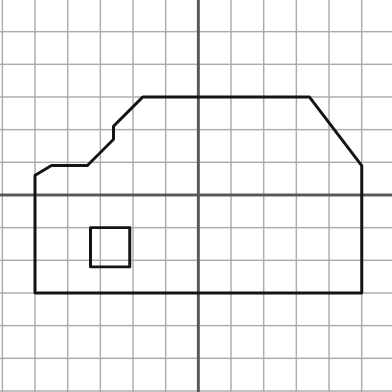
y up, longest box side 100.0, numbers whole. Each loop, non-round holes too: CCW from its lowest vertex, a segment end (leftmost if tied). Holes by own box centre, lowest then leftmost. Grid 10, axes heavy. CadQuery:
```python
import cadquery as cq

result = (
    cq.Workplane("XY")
    .moveTo(-50.0, -30.0)
    .lineTo(50.0, -30.0)
    .lineTo(50.0, 9.0)
    .lineTo(34.0, 30.0)
    .lineTo(-17.0, 30.0)
    .lineTo(-26.0, 21.0)
    .lineTo(-26.0, 17.0)
    .lineTo(-34.0, 9.0)
    .lineTo(-45.0, 9.0)
    .lineTo(-50.0, 6.0)
    .close()
    .moveTo(-33.0, -22.0)
    .lineTo(-21.0, -22.0)
    .lineTo(-21.0, -10.0)
    .lineTo(-33.0, -10.0)
    .close()
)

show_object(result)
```